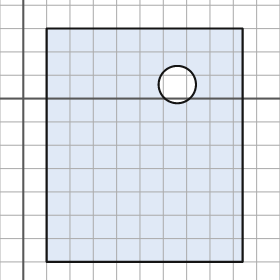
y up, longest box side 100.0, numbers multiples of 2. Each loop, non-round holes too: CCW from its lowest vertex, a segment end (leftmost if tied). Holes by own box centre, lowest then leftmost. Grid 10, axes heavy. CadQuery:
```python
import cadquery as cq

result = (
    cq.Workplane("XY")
    .moveTo(10.0, -70.0)
    .lineTo(94.0, -70.0)
    .lineTo(94.0, 30.0)
    .lineTo(10.0, 30.0)
    .close()
    .moveTo(66.0, 6.0)
    .circle(8.0)
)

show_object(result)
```